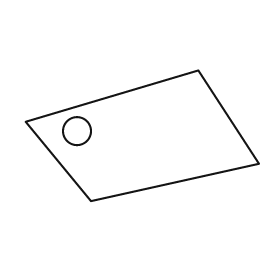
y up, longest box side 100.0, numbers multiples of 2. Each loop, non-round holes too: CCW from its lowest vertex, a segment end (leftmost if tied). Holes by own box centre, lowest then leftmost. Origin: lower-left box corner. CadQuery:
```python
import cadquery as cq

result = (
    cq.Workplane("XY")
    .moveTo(28.0, 0.0)
    .lineTo(100.0, 16.0)
    .lineTo(74.0, 56.0)
    .lineTo(0.0, 34.0)
    .close()
    .moveTo(22.0, 30.0)
    .circle(6.0)
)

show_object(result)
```